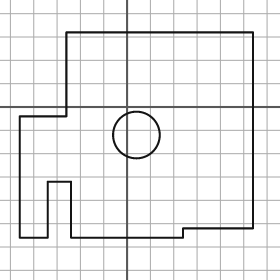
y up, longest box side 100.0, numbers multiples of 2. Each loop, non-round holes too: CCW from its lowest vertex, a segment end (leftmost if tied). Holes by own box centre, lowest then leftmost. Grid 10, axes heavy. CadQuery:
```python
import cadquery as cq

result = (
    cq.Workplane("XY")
    .moveTo(-46.0, -56.0)
    .lineTo(-34.0, -56.0)
    .lineTo(-34.0, -32.0)
    .lineTo(-24.0, -32.0)
    .lineTo(-24.0, -56.0)
    .lineTo(24.0, -56.0)
    .lineTo(24.0, -52.0)
    .lineTo(54.0, -52.0)
    .lineTo(54.0, 32.0)
    .lineTo(-26.0, 32.0)
    .lineTo(-26.0, -4.0)
    .lineTo(-46.0, -4.0)
    .close()
    .moveTo(4.0, -12.0)
    .circle(10.0)
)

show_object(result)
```